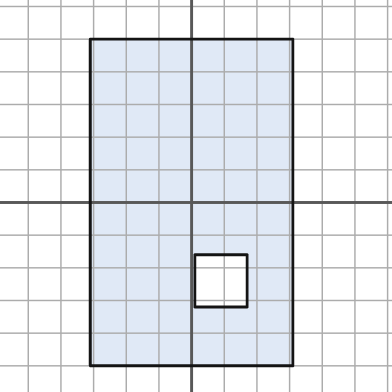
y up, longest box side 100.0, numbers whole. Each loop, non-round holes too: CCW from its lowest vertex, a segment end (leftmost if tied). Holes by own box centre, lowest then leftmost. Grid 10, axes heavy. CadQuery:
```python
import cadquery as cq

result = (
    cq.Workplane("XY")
    .moveTo(-31.0, -50.0)
    .lineTo(31.0, -50.0)
    .lineTo(31.0, 50.0)
    .lineTo(-31.0, 50.0)
    .close()
    .moveTo(1.0, -32.0)
    .lineTo(17.0, -32.0)
    .lineTo(17.0, -16.0)
    .lineTo(1.0, -16.0)
    .close()
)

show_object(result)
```